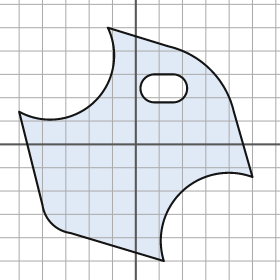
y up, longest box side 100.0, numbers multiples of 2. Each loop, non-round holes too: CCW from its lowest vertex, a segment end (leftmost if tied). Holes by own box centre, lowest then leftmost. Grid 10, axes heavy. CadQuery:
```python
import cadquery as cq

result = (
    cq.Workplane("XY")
    .moveTo(12.0, -50.0)
    .threePointArc((20.0, -20.0), (50.0, -14.0))
    .lineTo(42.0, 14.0)
    .threePointArc((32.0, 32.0), (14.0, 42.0))
    .lineTo(-12.0, 50.0)
    .threePointArc((-18.0, 18.0), (-50.0, 14.0))
    .lineTo(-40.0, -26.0)
    .threePointArc((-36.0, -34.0), (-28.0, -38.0))
    .close()
    .moveTo(8.0, 18.0)
    .lineTo(16.0, 18.0)
    .threePointArc((22.0, 24.0), (16.0, 30.0))
    .lineTo(8.0, 30.0)
    .threePointArc((2.0, 24.0), (8.0, 18.0))
    .close()
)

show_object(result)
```